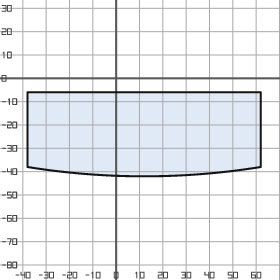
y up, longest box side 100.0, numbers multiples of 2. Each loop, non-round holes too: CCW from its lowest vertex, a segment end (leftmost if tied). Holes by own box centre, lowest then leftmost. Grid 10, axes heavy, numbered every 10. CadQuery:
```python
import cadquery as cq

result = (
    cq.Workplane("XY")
    .moveTo(-38.0, -38.0)
    .threePointArc((12.0, -42.0), (62.0, -38.0))
    .lineTo(62.0, -6.0)
    .lineTo(-38.0, -6.0)
    .close()
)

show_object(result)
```